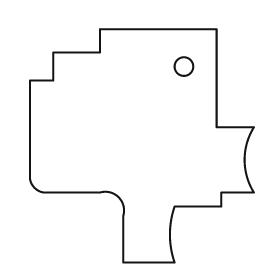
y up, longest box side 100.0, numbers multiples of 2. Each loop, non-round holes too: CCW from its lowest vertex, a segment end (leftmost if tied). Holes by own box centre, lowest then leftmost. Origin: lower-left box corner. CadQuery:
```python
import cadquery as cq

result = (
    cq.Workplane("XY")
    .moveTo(40.0, 0.0)
    .lineTo(62.0, 0.0)
    .threePointArc((60.0, 12.0), (62.0, 24.0))
    .lineTo(82.0, 24.0)
    .lineTo(82.0, 30.0)
    .lineTo(96.0, 30.0)
    .threePointArc((92.0, 44.0), (96.0, 58.0))
    .lineTo(80.0, 58.0)
    .lineTo(80.0, 100.0)
    .lineTo(30.0, 100.0)
    .lineTo(30.0, 90.0)
    .lineTo(10.0, 90.0)
    .lineTo(10.0, 78.0)
    .lineTo(0.0, 78.0)
    .lineTo(0.0, 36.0)
    .threePointArc((2.0, 32.0), (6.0, 30.0))
    .lineTo(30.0, 30.0)
    .threePointArc((38.0, 28.0), (40.0, 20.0))
    .close()
    .moveTo(66.0, 84.0)
    .circle(4.0)
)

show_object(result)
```